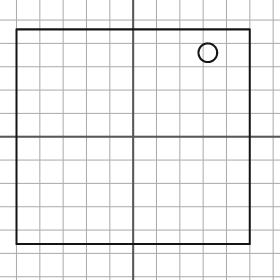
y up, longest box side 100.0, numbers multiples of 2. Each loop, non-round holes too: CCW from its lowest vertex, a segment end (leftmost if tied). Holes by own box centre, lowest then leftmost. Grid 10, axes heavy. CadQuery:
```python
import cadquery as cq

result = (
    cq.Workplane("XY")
    .moveTo(-50.0, -46.0)
    .lineTo(50.0, -46.0)
    .lineTo(50.0, 46.0)
    .lineTo(-50.0, 46.0)
    .close()
    .moveTo(32.0, 36.0)
    .circle(4.0)
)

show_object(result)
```